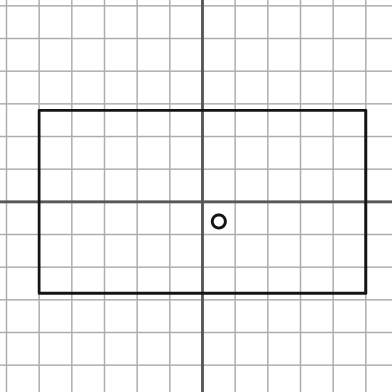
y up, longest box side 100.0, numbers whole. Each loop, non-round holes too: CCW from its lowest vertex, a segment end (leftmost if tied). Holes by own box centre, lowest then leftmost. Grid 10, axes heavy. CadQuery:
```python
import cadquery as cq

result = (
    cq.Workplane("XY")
    .moveTo(-50.0, -28.0)
    .lineTo(50.0, -28.0)
    .lineTo(50.0, 28.0)
    .lineTo(-50.0, 28.0)
    .close()
    .moveTo(5.0, -6.0)
    .circle(2.0)
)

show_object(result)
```